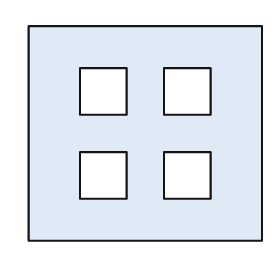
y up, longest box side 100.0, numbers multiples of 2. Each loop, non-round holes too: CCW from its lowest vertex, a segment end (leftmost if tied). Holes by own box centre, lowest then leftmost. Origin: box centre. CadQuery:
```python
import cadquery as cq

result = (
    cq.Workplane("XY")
    .moveTo(-50.0, -46.0)
    .lineTo(50.0, -46.0)
    .lineTo(50.0, 46.0)
    .lineTo(-50.0, 46.0)
    .close()
    .moveTo(-28.0, -28.0)
    .lineTo(-8.0, -28.0)
    .lineTo(-8.0, -8.0)
    .lineTo(-28.0, -8.0)
    .close()
    .moveTo(8.0, -28.0)
    .lineTo(28.0, -28.0)
    .lineTo(28.0, -8.0)
    .lineTo(8.0, -8.0)
    .close()
    .moveTo(-28.0, 8.0)
    .lineTo(-8.0, 8.0)
    .lineTo(-8.0, 28.0)
    .lineTo(-28.0, 28.0)
    .close()
    .moveTo(8.0, 8.0)
    .lineTo(28.0, 8.0)
    .lineTo(28.0, 28.0)
    .lineTo(8.0, 28.0)
    .close()
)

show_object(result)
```